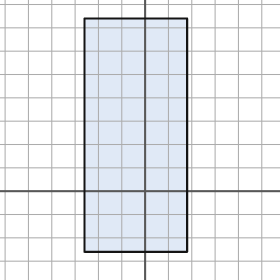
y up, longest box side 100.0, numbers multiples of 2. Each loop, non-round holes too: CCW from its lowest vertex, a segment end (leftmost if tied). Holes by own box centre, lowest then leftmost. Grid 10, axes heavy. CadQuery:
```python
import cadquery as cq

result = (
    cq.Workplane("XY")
    .moveTo(-26.0, -26.0)
    .lineTo(18.0, -26.0)
    .lineTo(18.0, 74.0)
    .lineTo(-26.0, 74.0)
    .close()
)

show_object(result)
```